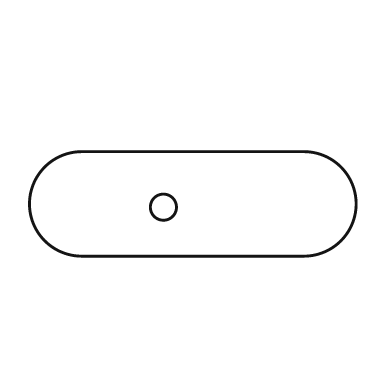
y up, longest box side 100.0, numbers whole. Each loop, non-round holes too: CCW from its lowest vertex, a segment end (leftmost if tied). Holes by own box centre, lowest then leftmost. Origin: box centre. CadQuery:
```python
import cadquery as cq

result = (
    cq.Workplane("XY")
    .moveTo(-34.0, -16.0)
    .lineTo(34.0, -16.0)
    .threePointArc((50.0, 0.0), (34.0, 16.0))
    .lineTo(-34.0, 16.0)
    .threePointArc((-50.0, 0.0), (-34.0, -16.0))
    .close()
    .moveTo(-9.0, -1.0)
    .circle(4.0)
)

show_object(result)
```